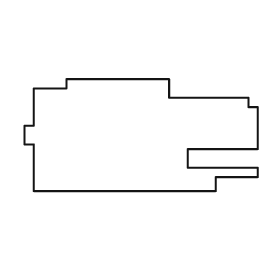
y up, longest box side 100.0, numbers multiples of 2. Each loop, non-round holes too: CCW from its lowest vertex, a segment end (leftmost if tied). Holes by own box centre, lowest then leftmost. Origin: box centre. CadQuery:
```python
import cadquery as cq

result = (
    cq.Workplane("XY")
    .moveTo(-46.0, -24.0)
    .lineTo(32.0, -24.0)
    .lineTo(32.0, -18.0)
    .lineTo(50.0, -18.0)
    .lineTo(50.0, -14.0)
    .lineTo(20.0, -14.0)
    .lineTo(20.0, -6.0)
    .lineTo(50.0, -6.0)
    .lineTo(50.0, 12.0)
    .lineTo(46.0, 12.0)
    .lineTo(46.0, 16.0)
    .lineTo(12.0, 16.0)
    .lineTo(12.0, 24.0)
    .lineTo(-32.0, 24.0)
    .lineTo(-32.0, 20.0)
    .lineTo(-46.0, 20.0)
    .lineTo(-46.0, 4.0)
    .lineTo(-50.0, 4.0)
    .lineTo(-50.0, -4.0)
    .lineTo(-46.0, -4.0)
    .close()
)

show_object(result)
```